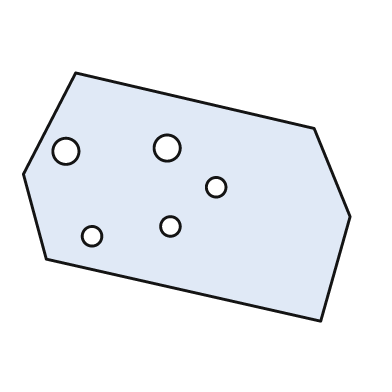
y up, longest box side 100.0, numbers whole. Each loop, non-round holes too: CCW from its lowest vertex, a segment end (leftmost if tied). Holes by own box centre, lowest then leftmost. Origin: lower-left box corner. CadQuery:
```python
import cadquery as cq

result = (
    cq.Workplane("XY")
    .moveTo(91.0, 0.0)
    .lineTo(100.0, 32.0)
    .lineTo(89.0, 59.0)
    .lineTo(16.0, 76.0)
    .lineTo(0.0, 45.0)
    .lineTo(7.0, 19.0)
    .close()
    .moveTo(21.0, 26.0)
    .circle(3.0)
    .moveTo(45.0, 29.0)
    .circle(3.0)
    .moveTo(59.0, 41.0)
    .circle(3.0)
    .moveTo(13.0, 52.0)
    .circle(4.0)
    .moveTo(44.0, 53.0)
    .circle(4.0)
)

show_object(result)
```